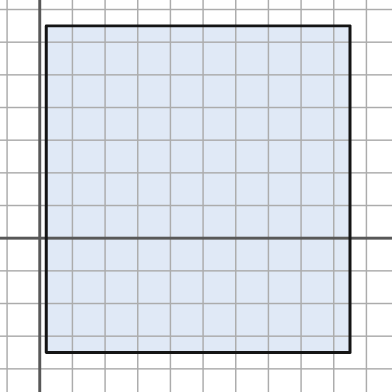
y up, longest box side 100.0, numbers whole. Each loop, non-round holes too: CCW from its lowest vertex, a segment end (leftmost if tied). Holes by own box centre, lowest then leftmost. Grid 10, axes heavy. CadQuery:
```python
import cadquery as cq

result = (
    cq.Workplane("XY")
    .moveTo(2.0, -35.0)
    .lineTo(95.0, -35.0)
    .lineTo(95.0, 65.0)
    .lineTo(2.0, 65.0)
    .close()
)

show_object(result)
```